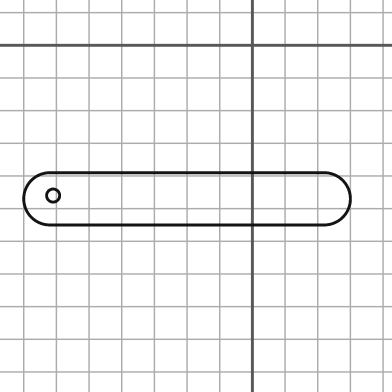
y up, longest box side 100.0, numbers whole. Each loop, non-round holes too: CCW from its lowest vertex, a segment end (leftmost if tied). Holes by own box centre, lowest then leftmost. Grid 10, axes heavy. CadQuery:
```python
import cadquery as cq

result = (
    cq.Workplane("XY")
    .moveTo(-62.0, -55.0)
    .lineTo(22.0, -55.0)
    .threePointArc((30.0, -47.0), (22.0, -39.0))
    .lineTo(-62.0, -39.0)
    .threePointArc((-70.0, -47.0), (-62.0, -55.0))
    .close()
    .moveTo(-61.0, -46.0)
    .circle(2.0)
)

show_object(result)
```